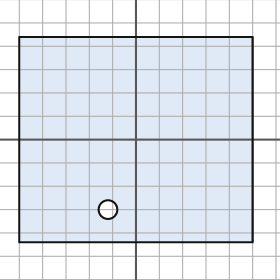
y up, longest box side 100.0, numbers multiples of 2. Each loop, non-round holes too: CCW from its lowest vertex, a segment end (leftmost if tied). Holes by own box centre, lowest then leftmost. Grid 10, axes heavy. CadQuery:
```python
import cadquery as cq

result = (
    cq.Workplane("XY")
    .moveTo(-50.0, -44.0)
    .lineTo(50.0, -44.0)
    .lineTo(50.0, 44.0)
    .lineTo(-50.0, 44.0)
    .close()
    .moveTo(-12.0, -30.0)
    .circle(4.0)
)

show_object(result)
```